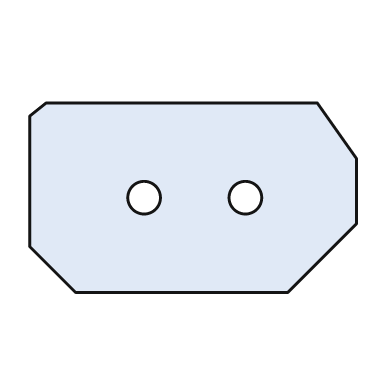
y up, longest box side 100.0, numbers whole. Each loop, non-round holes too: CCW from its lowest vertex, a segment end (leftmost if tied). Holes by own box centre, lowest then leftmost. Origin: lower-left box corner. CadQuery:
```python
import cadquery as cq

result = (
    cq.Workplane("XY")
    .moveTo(14.0, 0.0)
    .lineTo(79.0, 0.0)
    .lineTo(100.0, 21.0)
    .lineTo(100.0, 41.0)
    .lineTo(88.0, 58.0)
    .lineTo(5.0, 58.0)
    .lineTo(0.0, 54.0)
    .lineTo(0.0, 14.0)
    .close()
    .moveTo(35.0, 29.0)
    .circle(5.0)
    .moveTo(66.0, 29.0)
    .circle(5.0)
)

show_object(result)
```